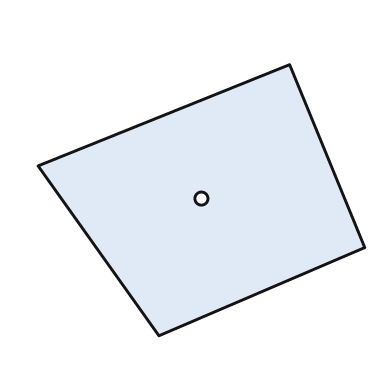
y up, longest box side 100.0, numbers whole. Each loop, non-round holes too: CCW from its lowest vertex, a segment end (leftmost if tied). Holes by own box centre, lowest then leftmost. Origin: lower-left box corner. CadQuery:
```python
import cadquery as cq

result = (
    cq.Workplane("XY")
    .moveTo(37.0, 0.0)
    .lineTo(100.0, 27.0)
    .lineTo(77.0, 83.0)
    .lineTo(0.0, 52.0)
    .close()
    .moveTo(50.0, 42.0)
    .circle(2.0)
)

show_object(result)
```